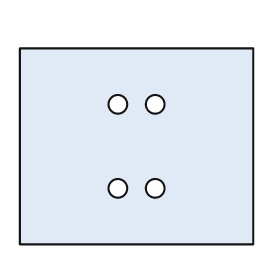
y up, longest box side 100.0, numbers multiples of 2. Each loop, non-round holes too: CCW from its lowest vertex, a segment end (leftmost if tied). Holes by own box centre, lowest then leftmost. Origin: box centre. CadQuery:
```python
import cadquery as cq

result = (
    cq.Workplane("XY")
    .moveTo(-50.0, -42.0)
    .lineTo(50.0, -42.0)
    .lineTo(50.0, 42.0)
    .lineTo(-50.0, 42.0)
    .close()
    .moveTo(-8.0, -18.0)
    .circle(4.0)
    .moveTo(8.0, -18.0)
    .circle(4.0)
    .moveTo(-8.0, 18.0)
    .circle(4.0)
    .moveTo(8.0, 18.0)
    .circle(4.0)
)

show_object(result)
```